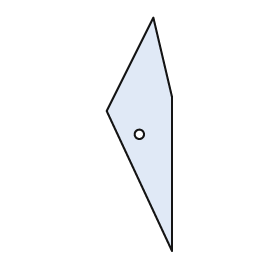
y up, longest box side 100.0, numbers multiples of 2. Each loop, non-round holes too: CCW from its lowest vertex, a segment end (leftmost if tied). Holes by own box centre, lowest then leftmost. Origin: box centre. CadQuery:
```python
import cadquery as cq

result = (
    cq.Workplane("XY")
    .moveTo(14.0, -50.0)
    .lineTo(14.0, 16.0)
    .lineTo(6.0, 50.0)
    .lineTo(-14.0, 10.0)
    .close()
    .moveTo(0.0, 0.0)
    .circle(2.0)
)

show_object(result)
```